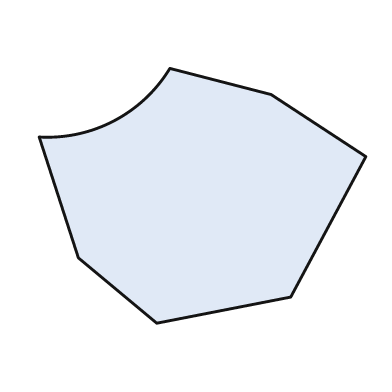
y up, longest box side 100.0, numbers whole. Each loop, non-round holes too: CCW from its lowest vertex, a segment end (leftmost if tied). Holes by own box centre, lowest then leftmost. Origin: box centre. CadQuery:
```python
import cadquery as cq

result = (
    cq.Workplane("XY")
    .moveTo(-14.0, -39.0)
    .lineTo(27.0, -31.0)
    .lineTo(50.0, 12.0)
    .lineTo(21.0, 31.0)
    .lineTo(-10.0, 39.0)
    .threePointArc((-27.0, 23.0), (-50.0, 18.0))
    .lineTo(-38.0, -19.0)
    .close()
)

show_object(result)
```